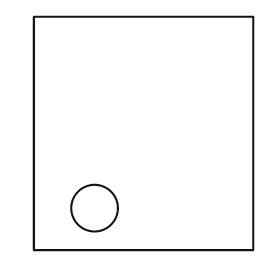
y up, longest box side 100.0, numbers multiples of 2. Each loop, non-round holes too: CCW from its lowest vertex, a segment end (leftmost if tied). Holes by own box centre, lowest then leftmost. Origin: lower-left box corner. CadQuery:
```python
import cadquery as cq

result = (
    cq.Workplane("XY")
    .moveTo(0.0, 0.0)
    .lineTo(94.0, 0.0)
    .lineTo(94.0, 100.0)
    .lineTo(0.0, 100.0)
    .close()
    .moveTo(26.0, 18.0)
    .circle(10.0)
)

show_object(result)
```